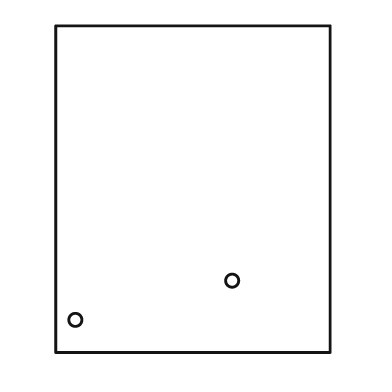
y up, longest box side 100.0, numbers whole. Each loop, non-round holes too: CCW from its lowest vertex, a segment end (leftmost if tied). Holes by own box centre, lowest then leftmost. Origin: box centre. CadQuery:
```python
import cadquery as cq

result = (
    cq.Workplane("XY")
    .moveTo(-42.0, -50.0)
    .lineTo(42.0, -50.0)
    .lineTo(42.0, 50.0)
    .lineTo(-42.0, 50.0)
    .close()
    .moveTo(-36.0, -40.0)
    .circle(2.0)
    .moveTo(12.0, -28.0)
    .circle(2.0)
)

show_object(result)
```